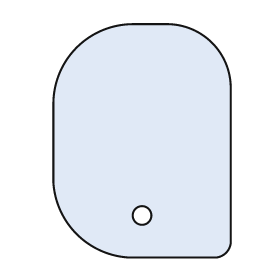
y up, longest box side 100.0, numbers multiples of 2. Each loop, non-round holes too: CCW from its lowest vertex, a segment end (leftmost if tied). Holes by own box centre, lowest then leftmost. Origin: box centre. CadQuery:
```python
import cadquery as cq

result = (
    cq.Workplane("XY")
    .moveTo(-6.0, -50.0)
    .lineTo(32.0, -50.0)
    .threePointArc((36.0, -48.0), (38.0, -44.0))
    .lineTo(38.0, 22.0)
    .threePointArc((30.0, 42.0), (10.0, 50.0))
    .lineTo(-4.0, 50.0)
    .threePointArc((-28.0, 40.0), (-38.0, 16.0))
    .lineTo(-38.0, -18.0)
    .threePointArc((-28.0, -40.0), (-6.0, -50.0))
    .close()
    .moveTo(0.0, -32.0)
    .circle(4.0)
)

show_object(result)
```